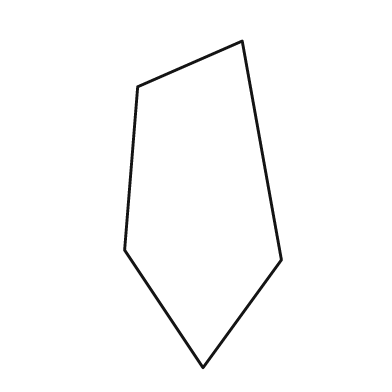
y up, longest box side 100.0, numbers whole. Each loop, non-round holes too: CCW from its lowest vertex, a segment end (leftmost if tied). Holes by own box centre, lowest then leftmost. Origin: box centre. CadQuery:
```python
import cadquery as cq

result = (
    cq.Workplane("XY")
    .moveTo(0.0, -50.0)
    .lineTo(24.0, -17.0)
    .lineTo(12.0, 50.0)
    .lineTo(-20.0, 36.0)
    .lineTo(-24.0, -14.0)
    .close()
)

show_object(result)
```